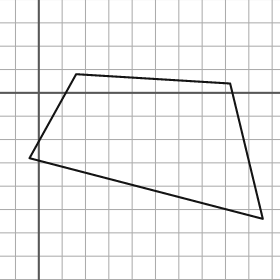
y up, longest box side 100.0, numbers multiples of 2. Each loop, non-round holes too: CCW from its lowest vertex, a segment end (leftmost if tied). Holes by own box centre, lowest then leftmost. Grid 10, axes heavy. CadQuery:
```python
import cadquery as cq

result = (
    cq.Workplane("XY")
    .moveTo(96.0, -54.0)
    .lineTo(82.0, 4.0)
    .lineTo(16.0, 8.0)
    .lineTo(-4.0, -28.0)
    .close()
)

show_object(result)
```